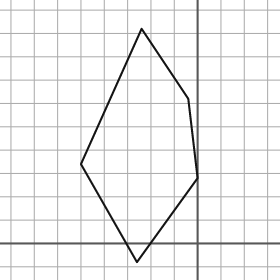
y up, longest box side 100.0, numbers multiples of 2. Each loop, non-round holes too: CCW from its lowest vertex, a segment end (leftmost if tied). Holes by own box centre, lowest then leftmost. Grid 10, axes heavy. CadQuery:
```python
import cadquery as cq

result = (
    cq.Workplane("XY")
    .moveTo(-26.0, -8.0)
    .lineTo(0.0, 28.0)
    .lineTo(-4.0, 62.0)
    .lineTo(-24.0, 92.0)
    .lineTo(-50.0, 34.0)
    .close()
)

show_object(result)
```